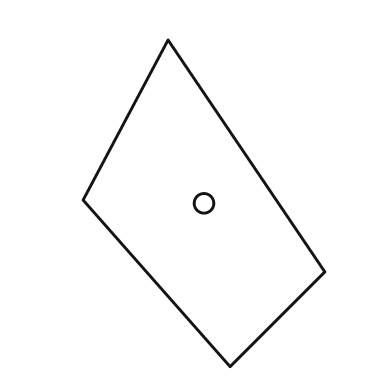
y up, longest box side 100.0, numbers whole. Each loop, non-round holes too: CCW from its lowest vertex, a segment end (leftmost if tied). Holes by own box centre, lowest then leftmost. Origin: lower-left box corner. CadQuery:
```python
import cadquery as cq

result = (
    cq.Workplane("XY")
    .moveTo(45.0, 0.0)
    .lineTo(74.0, 29.0)
    .lineTo(26.0, 100.0)
    .lineTo(0.0, 51.0)
    .close()
    .moveTo(37.0, 50.0)
    .circle(3.0)
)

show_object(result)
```